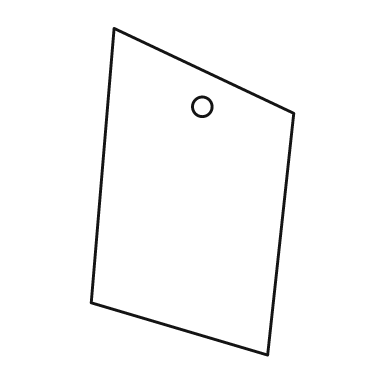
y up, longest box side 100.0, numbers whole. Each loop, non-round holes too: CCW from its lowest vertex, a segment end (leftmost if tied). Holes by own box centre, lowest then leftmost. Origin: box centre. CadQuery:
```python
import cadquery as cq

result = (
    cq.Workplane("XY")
    .moveTo(23.0, -50.0)
    .lineTo(31.0, 24.0)
    .lineTo(-24.0, 50.0)
    .lineTo(-31.0, -34.0)
    .close()
    .moveTo(3.0, 26.0)
    .circle(3.0)
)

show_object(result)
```